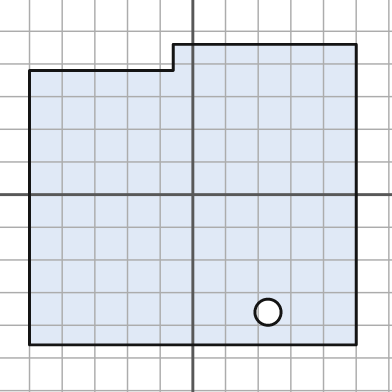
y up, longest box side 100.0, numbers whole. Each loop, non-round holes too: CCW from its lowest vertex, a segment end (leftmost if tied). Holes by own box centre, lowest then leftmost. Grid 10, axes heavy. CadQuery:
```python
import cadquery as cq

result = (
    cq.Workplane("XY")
    .moveTo(-50.0, -46.0)
    .lineTo(50.0, -46.0)
    .lineTo(50.0, 46.0)
    .lineTo(-6.0, 46.0)
    .lineTo(-6.0, 38.0)
    .lineTo(-50.0, 38.0)
    .close()
    .moveTo(23.0, -36.0)
    .circle(4.0)
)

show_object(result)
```